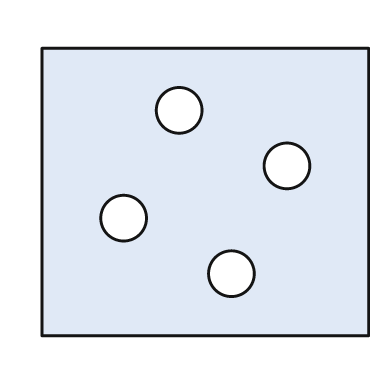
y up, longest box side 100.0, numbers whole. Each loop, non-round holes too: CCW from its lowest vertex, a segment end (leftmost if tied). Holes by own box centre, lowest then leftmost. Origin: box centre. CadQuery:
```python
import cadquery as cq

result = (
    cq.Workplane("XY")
    .moveTo(-50.0, -44.0)
    .lineTo(50.0, -44.0)
    .lineTo(50.0, 44.0)
    .lineTo(-50.0, 44.0)
    .close()
    .moveTo(8.0, -25.0)
    .circle(7.0)
    .moveTo(-25.0, -8.0)
    .circle(7.0)
    .moveTo(25.0, 8.0)
    .circle(7.0)
    .moveTo(-8.0, 25.0)
    .circle(7.0)
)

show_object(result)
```